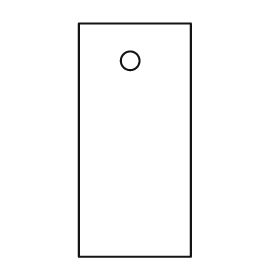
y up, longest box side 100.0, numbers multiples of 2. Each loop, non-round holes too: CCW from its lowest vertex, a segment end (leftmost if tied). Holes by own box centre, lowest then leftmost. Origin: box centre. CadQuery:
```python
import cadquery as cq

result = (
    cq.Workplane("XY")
    .moveTo(-24.0, -50.0)
    .lineTo(24.0, -50.0)
    .lineTo(24.0, 50.0)
    .lineTo(-24.0, 50.0)
    .close()
    .moveTo(-2.0, 34.0)
    .circle(4.0)
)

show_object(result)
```